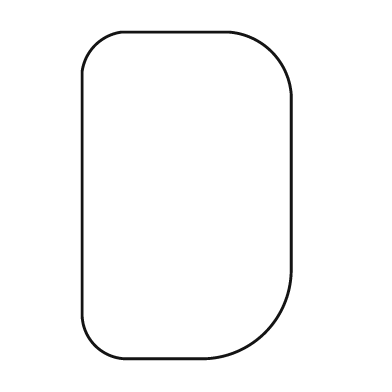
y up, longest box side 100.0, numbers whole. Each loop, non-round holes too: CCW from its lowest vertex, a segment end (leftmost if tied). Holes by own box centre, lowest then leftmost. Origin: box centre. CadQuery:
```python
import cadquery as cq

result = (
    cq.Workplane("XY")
    .moveTo(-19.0, -50.0)
    .lineTo(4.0, -50.0)
    .threePointArc((24.0, -42.0), (32.0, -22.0))
    .lineTo(32.0, 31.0)
    .threePointArc((26.0, 44.0), (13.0, 50.0))
    .lineTo(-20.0, 50.0)
    .threePointArc((-28.0, 46.0), (-32.0, 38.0))
    .lineTo(-32.0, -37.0)
    .threePointArc((-28.0, -46.0), (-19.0, -50.0))
    .close()
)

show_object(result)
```